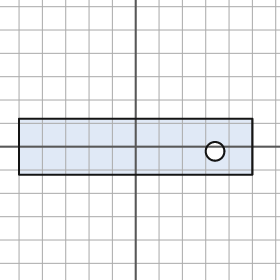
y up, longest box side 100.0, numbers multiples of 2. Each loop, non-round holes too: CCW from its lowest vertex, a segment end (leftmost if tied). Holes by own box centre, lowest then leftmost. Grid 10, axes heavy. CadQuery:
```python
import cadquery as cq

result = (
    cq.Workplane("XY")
    .moveTo(-50.0, -12.0)
    .lineTo(50.0, -12.0)
    .lineTo(50.0, 12.0)
    .lineTo(-50.0, 12.0)
    .close()
    .moveTo(34.0, -2.0)
    .circle(4.0)
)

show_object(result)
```